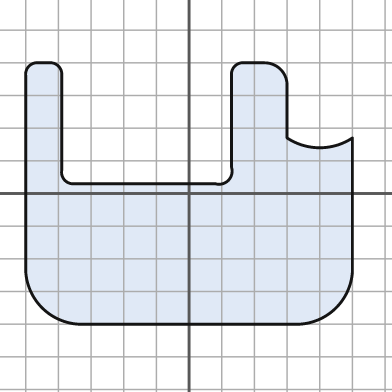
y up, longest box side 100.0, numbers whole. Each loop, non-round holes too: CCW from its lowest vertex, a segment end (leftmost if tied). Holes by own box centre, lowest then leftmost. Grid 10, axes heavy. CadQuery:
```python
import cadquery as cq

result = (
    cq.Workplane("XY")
    .moveTo(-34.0, -40.0)
    .lineTo(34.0, -40.0)
    .threePointArc((45.0, -35.0), (50.0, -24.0))
    .lineTo(50.0, 17.0)
    .threePointArc((40.0, 14.0), (30.0, 17.0))
    .lineTo(30.0, 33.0)
    .threePointArc((28.0, 38.0), (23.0, 40.0))
    .lineTo(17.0, 40.0)
    .threePointArc((14.0, 39.0), (13.0, 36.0))
    .lineTo(13.0, 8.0)
    .threePointArc((12.0, 4.0), (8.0, 3.0))
    .lineTo(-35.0, 3.0)
    .threePointArc((-38.0, 4.0), (-39.0, 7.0))
    .lineTo(-39.0, 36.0)
    .threePointArc((-40.0, 39.0), (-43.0, 40.0))
    .lineTo(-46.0, 40.0)
    .threePointArc((-49.0, 39.0), (-50.0, 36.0))
    .lineTo(-50.0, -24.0)
    .threePointArc((-45.0, -35.0), (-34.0, -40.0))
    .close()
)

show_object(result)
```